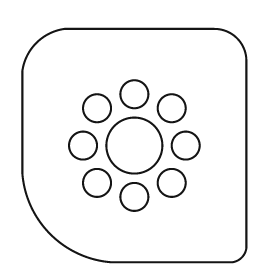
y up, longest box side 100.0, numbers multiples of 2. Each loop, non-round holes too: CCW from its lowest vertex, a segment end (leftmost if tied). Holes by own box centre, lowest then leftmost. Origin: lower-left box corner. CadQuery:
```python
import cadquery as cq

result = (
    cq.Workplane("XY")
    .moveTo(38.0, 0.0)
    .lineTo(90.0, 0.0)
    .threePointArc((94.0, 2.0), (96.0, 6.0))
    .lineTo(96.0, 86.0)
    .threePointArc((92.0, 96.0), (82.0, 100.0))
    .lineTo(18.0, 100.0)
    .threePointArc((6.0, 94.0), (0.0, 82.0))
    .lineTo(0.0, 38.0)
    .threePointArc((12.0, 12.0), (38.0, 0.0))
    .close()
    .moveTo(48.0, 28.0)
    .circle(6.0)
    .moveTo(32.0, 34.0)
    .circle(6.0)
    .moveTo(64.0, 34.0)
    .circle(6.0)
    .moveTo(26.0, 50.0)
    .circle(6.0)
    .moveTo(48.0, 50.0)
    .circle(12.0)
    .moveTo(70.0, 50.0)
    .circle(6.0)
    .moveTo(32.0, 66.0)
    .circle(6.0)
    .moveTo(64.0, 66.0)
    .circle(6.0)
    .moveTo(48.0, 72.0)
    .circle(6.0)
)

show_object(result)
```